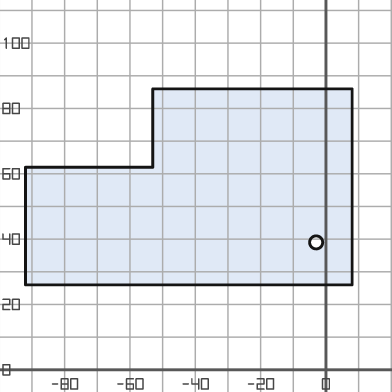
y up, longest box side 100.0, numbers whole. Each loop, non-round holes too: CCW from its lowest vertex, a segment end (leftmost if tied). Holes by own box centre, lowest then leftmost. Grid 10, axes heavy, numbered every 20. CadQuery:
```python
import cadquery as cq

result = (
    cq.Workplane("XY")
    .moveTo(-92.0, 26.0)
    .lineTo(8.0, 26.0)
    .lineTo(8.0, 86.0)
    .lineTo(-53.0, 86.0)
    .lineTo(-53.0, 62.0)
    .lineTo(-92.0, 62.0)
    .close()
    .moveTo(-3.0, 39.0)
    .circle(2.0)
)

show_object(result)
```